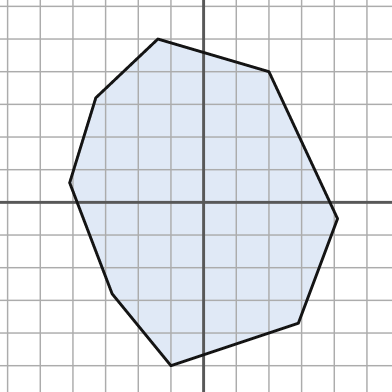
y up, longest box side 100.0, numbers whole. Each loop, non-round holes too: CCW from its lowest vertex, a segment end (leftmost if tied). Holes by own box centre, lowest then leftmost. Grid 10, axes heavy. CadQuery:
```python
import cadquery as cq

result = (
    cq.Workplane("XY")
    .moveTo(-10.0, -50.0)
    .lineTo(29.0, -37.0)
    .lineTo(41.0, -5.0)
    .lineTo(20.0, 40.0)
    .lineTo(-14.0, 50.0)
    .lineTo(-33.0, 32.0)
    .lineTo(-41.0, 6.0)
    .lineTo(-28.0, -28.0)
    .close()
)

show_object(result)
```